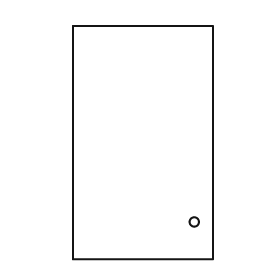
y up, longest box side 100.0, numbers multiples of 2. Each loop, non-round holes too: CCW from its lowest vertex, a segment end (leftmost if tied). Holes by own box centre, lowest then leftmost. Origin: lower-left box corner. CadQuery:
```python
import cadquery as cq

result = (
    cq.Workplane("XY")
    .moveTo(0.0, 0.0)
    .lineTo(60.0, 0.0)
    .lineTo(60.0, 100.0)
    .lineTo(0.0, 100.0)
    .close()
    .moveTo(52.0, 16.0)
    .circle(2.0)
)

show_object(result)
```